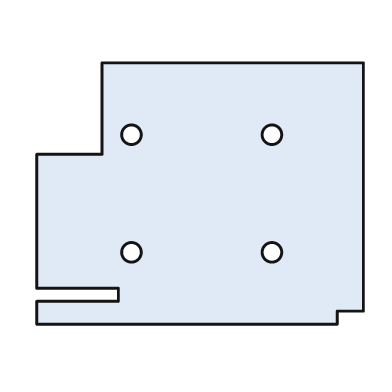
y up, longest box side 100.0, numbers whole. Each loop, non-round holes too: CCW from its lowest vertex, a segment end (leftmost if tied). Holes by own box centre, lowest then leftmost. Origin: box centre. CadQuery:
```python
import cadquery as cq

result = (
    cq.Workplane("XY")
    .moveTo(-50.0, -40.0)
    .lineTo(42.0, -40.0)
    .lineTo(42.0, -36.0)
    .lineTo(50.0, -36.0)
    .lineTo(50.0, 40.0)
    .lineTo(-30.0, 40.0)
    .lineTo(-30.0, 12.0)
    .lineTo(-50.0, 12.0)
    .lineTo(-50.0, -29.0)
    .lineTo(-25.0, -29.0)
    .lineTo(-25.0, -33.0)
    .lineTo(-50.0, -33.0)
    .close()
    .moveTo(-21.0, -18.0)
    .circle(3.0)
    .moveTo(22.0, -18.0)
    .circle(3.0)
    .moveTo(-21.0, 18.0)
    .circle(3.0)
    .moveTo(22.0, 18.0)
    .circle(3.0)
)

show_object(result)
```